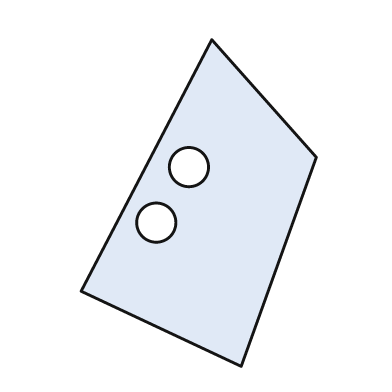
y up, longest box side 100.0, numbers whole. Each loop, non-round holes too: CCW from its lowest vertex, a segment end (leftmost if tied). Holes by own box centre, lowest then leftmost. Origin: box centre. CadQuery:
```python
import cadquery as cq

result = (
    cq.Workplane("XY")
    .moveTo(13.0, -50.0)
    .lineTo(36.0, 14.0)
    .lineTo(4.0, 50.0)
    .lineTo(-36.0, -27.0)
    .close()
    .moveTo(-13.0, -6.0)
    .circle(6.0)
    .moveTo(-3.0, 11.0)
    .circle(6.0)
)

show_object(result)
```